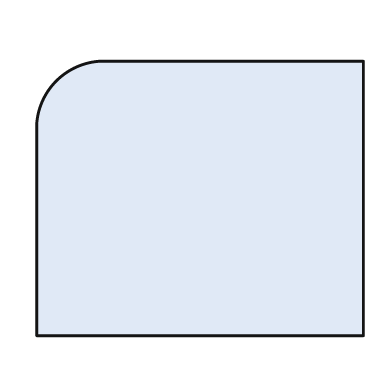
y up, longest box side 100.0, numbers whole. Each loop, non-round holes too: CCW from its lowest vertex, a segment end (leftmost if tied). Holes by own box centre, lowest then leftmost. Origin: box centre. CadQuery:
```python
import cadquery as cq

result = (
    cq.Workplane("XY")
    .moveTo(-50.0, -42.0)
    .lineTo(50.0, -42.0)
    .lineTo(50.0, 42.0)
    .lineTo(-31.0, 42.0)
    .threePointArc((-44.0, 36.0), (-50.0, 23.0))
    .close()
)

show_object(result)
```